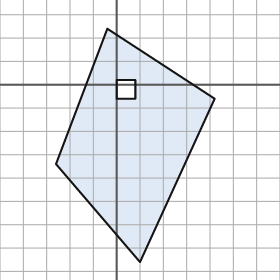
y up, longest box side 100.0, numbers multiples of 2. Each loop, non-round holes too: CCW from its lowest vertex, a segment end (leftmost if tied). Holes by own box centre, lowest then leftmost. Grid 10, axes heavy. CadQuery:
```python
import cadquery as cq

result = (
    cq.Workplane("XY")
    .moveTo(10.0, -76.0)
    .lineTo(42.0, -6.0)
    .lineTo(-4.0, 24.0)
    .lineTo(-26.0, -34.0)
    .close()
    .moveTo(0.0, -6.0)
    .lineTo(8.0, -6.0)
    .lineTo(8.0, 2.0)
    .lineTo(0.0, 2.0)
    .close()
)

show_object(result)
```